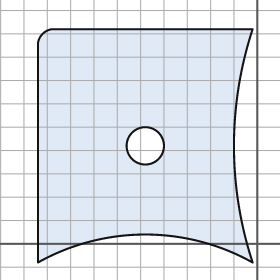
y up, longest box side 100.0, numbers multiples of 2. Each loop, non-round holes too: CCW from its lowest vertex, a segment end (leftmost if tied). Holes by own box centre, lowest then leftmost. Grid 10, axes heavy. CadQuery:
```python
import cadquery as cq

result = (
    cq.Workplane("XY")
    .moveTo(-94.0, -8.0)
    .threePointArc((-48.0, 4.0), (-2.0, -8.0))
    .threePointArc((-10.0, 42.0), (-2.0, 92.0))
    .lineTo(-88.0, 92.0)
    .threePointArc((-92.0, 90.0), (-94.0, 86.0))
    .close()
    .moveTo(-48.0, 42.0)
    .circle(8.0)
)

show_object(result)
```